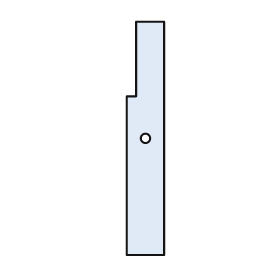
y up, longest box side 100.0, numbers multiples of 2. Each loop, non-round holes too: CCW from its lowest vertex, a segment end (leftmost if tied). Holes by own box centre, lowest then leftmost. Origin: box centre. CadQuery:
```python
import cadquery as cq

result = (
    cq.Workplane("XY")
    .moveTo(-8.0, -50.0)
    .lineTo(8.0, -50.0)
    .lineTo(8.0, 50.0)
    .lineTo(-4.0, 50.0)
    .lineTo(-4.0, 18.0)
    .lineTo(-8.0, 18.0)
    .close()
    .moveTo(0.0, 0.0)
    .circle(2.0)
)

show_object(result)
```